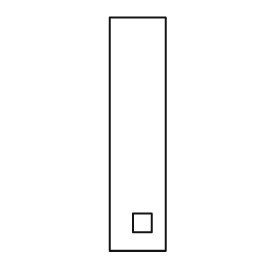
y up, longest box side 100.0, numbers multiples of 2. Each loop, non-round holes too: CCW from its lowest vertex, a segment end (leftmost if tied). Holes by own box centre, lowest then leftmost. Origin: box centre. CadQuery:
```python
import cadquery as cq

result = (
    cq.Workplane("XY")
    .moveTo(-12.0, -50.0)
    .lineTo(12.0, -50.0)
    .lineTo(12.0, 50.0)
    .lineTo(-12.0, 50.0)
    .close()
    .moveTo(-2.0, -42.0)
    .lineTo(6.0, -42.0)
    .lineTo(6.0, -34.0)
    .lineTo(-2.0, -34.0)
    .close()
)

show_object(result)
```